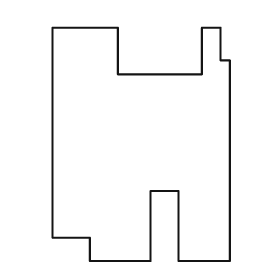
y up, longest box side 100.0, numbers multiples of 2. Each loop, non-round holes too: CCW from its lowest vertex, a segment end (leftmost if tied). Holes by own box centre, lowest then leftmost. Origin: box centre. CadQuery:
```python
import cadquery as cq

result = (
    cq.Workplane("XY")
    .moveTo(-22.0, -50.0)
    .lineTo(4.0, -50.0)
    .lineTo(4.0, -20.0)
    .lineTo(16.0, -20.0)
    .lineTo(16.0, -50.0)
    .lineTo(38.0, -50.0)
    .lineTo(38.0, 36.0)
    .lineTo(34.0, 36.0)
    .lineTo(34.0, 50.0)
    .lineTo(26.0, 50.0)
    .lineTo(26.0, 30.0)
    .lineTo(-10.0, 30.0)
    .lineTo(-10.0, 50.0)
    .lineTo(-38.0, 50.0)
    .lineTo(-38.0, -40.0)
    .lineTo(-22.0, -40.0)
    .close()
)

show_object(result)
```